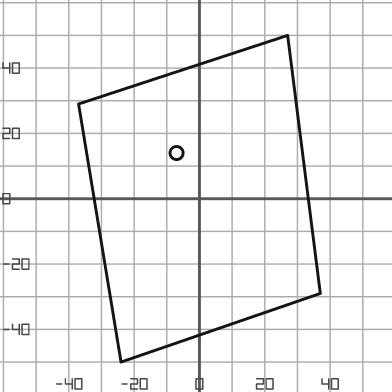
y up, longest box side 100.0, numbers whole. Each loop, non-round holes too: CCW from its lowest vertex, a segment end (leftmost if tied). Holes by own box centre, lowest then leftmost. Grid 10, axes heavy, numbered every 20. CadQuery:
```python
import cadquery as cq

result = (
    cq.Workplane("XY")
    .moveTo(-24.0, -50.0)
    .lineTo(37.0, -29.0)
    .lineTo(27.0, 50.0)
    .lineTo(-37.0, 29.0)
    .close()
    .moveTo(-7.0, 14.0)
    .circle(2.0)
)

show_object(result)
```